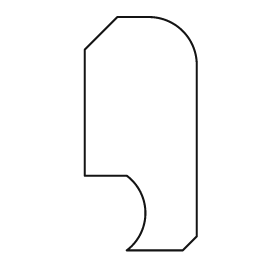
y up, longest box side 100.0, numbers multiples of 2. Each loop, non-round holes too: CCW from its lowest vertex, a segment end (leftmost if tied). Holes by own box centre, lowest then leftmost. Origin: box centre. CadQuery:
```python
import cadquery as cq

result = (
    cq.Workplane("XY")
    .moveTo(-6.0, -50.0)
    .lineTo(18.0, -50.0)
    .lineTo(24.0, -44.0)
    .lineTo(24.0, 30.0)
    .threePointArc((18.0, 44.0), (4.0, 50.0))
    .lineTo(-10.0, 50.0)
    .lineTo(-24.0, 36.0)
    .lineTo(-24.0, -18.0)
    .lineTo(-6.0, -18.0)
    .threePointArc((2.0, -34.0), (-6.0, -50.0))
    .close()
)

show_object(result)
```